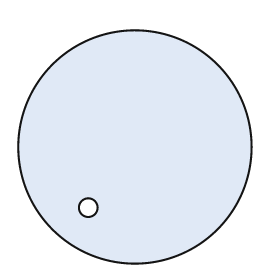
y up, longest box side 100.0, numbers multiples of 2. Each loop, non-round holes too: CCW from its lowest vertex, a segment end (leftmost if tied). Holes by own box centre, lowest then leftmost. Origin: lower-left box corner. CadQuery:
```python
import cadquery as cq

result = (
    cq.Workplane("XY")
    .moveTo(50.0, 50.0)
    .circle(50.0)
    .moveTo(30.0, 24.0)
    .circle(4.0)
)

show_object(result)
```